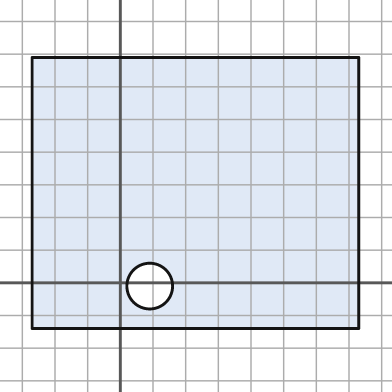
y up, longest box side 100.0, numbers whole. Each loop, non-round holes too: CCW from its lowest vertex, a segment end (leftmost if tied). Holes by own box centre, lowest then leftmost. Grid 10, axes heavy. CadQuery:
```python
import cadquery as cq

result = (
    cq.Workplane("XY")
    .moveTo(-27.0, -14.0)
    .lineTo(73.0, -14.0)
    .lineTo(73.0, 69.0)
    .lineTo(-27.0, 69.0)
    .close()
    .moveTo(9.0, -1.0)
    .circle(7.0)
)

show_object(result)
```